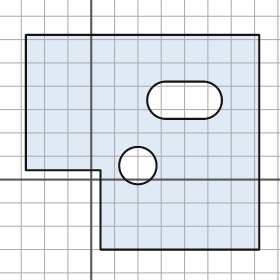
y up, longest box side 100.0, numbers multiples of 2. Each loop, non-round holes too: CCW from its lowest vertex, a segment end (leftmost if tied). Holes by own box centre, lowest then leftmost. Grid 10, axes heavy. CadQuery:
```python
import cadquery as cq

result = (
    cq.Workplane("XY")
    .moveTo(4.0, -30.0)
    .lineTo(72.0, -30.0)
    .lineTo(72.0, 62.0)
    .lineTo(-28.0, 62.0)
    .lineTo(-28.0, 4.0)
    .lineTo(4.0, 4.0)
    .close()
    .moveTo(20.0, 6.0)
    .circle(8.0)
    .moveTo(32.0, 26.0)
    .lineTo(48.0, 26.0)
    .threePointArc((56.0, 34.0), (48.0, 42.0))
    .lineTo(32.0, 42.0)
    .threePointArc((24.0, 34.0), (32.0, 26.0))
    .close()
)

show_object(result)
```